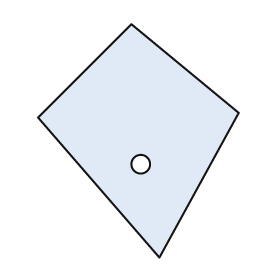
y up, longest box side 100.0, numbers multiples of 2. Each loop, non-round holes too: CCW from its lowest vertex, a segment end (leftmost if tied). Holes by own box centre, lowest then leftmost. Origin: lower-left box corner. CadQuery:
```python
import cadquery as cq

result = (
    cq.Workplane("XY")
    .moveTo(52.0, 0.0)
    .lineTo(86.0, 62.0)
    .lineTo(40.0, 100.0)
    .lineTo(0.0, 60.0)
    .close()
    .moveTo(44.0, 40.0)
    .circle(4.0)
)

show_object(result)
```